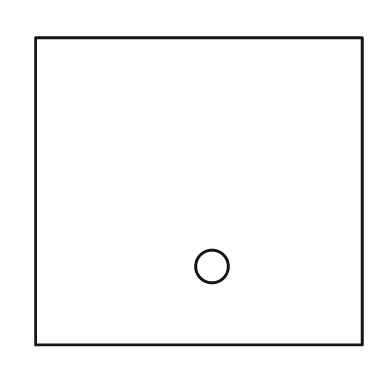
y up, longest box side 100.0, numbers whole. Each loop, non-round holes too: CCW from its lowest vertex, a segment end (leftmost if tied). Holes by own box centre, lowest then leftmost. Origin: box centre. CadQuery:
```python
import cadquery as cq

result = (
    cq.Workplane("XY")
    .moveTo(-50.0, -47.0)
    .lineTo(50.0, -47.0)
    .lineTo(50.0, 47.0)
    .lineTo(-50.0, 47.0)
    .close()
    .moveTo(4.0, -23.0)
    .circle(5.0)
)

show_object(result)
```